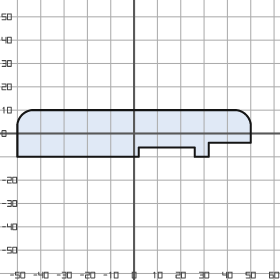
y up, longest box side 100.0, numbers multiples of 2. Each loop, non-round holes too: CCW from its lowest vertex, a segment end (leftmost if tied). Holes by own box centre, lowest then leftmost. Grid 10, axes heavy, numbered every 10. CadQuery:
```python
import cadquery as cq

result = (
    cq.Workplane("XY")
    .moveTo(-50.0, -10.0)
    .lineTo(2.0, -10.0)
    .lineTo(2.0, -6.0)
    .lineTo(26.0, -6.0)
    .lineTo(26.0, -10.0)
    .lineTo(32.0, -10.0)
    .lineTo(32.0, -4.0)
    .lineTo(50.0, -4.0)
    .lineTo(50.0, 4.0)
    .threePointArc((48.0, 8.0), (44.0, 10.0))
    .lineTo(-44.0, 10.0)
    .threePointArc((-48.0, 8.0), (-50.0, 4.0))
    .close()
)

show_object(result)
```